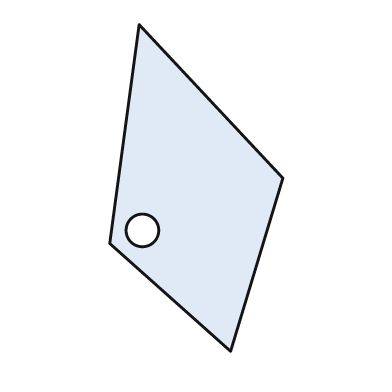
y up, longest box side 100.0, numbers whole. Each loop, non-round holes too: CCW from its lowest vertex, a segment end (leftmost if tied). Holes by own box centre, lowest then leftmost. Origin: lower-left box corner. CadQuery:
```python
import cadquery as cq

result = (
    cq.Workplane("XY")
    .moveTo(37.0, 0.0)
    .lineTo(53.0, 53.0)
    .lineTo(9.0, 100.0)
    .lineTo(0.0, 33.0)
    .close()
    .moveTo(10.0, 37.0)
    .circle(5.0)
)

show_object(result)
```